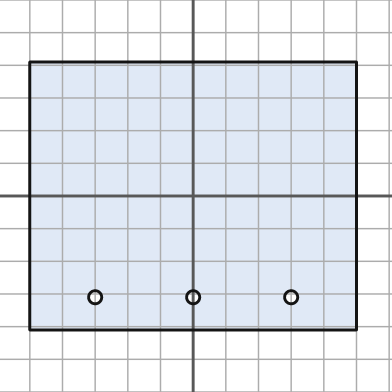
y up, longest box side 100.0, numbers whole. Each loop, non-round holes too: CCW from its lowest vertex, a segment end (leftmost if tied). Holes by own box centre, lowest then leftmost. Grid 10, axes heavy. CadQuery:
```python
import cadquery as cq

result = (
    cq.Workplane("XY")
    .moveTo(-50.0, -41.0)
    .lineTo(50.0, -41.0)
    .lineTo(50.0, 41.0)
    .lineTo(-50.0, 41.0)
    .close()
    .moveTo(-30.0, -31.0)
    .circle(2.0)
    .moveTo(0.0, -31.0)
    .circle(2.0)
    .moveTo(30.0, -31.0)
    .circle(2.0)
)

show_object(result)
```